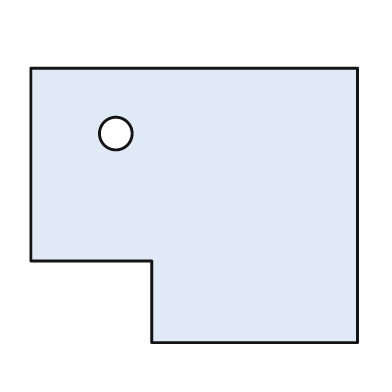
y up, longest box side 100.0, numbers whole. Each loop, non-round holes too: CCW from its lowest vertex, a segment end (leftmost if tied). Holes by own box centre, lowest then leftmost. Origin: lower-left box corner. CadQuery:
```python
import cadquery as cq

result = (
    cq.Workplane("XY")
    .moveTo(37.0, 0.0)
    .lineTo(100.0, 0.0)
    .lineTo(100.0, 84.0)
    .lineTo(0.0, 84.0)
    .lineTo(0.0, 25.0)
    .lineTo(37.0, 25.0)
    .close()
    .moveTo(26.0, 64.0)
    .circle(5.0)
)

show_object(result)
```